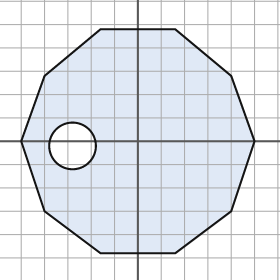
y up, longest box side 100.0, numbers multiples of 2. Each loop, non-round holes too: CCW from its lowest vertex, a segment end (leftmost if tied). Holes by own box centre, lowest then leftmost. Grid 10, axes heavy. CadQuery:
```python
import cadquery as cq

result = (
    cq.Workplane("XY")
    .moveTo(-16.0, -48.0)
    .lineTo(16.0, -48.0)
    .lineTo(40.0, -30.0)
    .lineTo(50.0, 0.0)
    .lineTo(40.0, 28.0)
    .lineTo(16.0, 48.0)
    .lineTo(-16.0, 48.0)
    .lineTo(-40.0, 28.0)
    .lineTo(-50.0, 0.0)
    .lineTo(-40.0, -30.0)
    .close()
    .moveTo(-28.0, -2.0)
    .circle(10.0)
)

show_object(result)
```